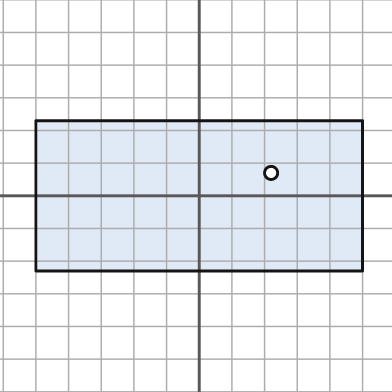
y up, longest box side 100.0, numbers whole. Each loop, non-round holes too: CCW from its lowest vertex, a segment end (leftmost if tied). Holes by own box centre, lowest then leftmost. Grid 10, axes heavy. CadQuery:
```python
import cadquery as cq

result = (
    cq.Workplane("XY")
    .moveTo(-50.0, -23.0)
    .lineTo(50.0, -23.0)
    .lineTo(50.0, 23.0)
    .lineTo(-50.0, 23.0)
    .close()
    .moveTo(22.0, 7.0)
    .circle(2.0)
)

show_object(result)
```